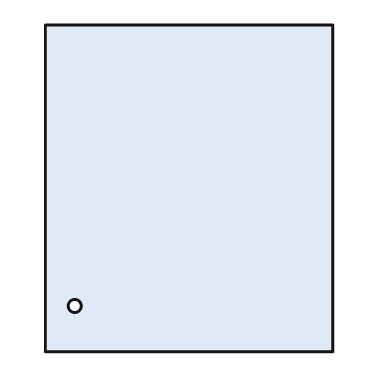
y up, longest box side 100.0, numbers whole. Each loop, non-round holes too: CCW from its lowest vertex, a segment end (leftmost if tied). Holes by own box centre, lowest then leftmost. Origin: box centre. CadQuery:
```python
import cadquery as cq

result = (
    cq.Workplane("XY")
    .moveTo(-44.0, -50.0)
    .lineTo(44.0, -50.0)
    .lineTo(44.0, 50.0)
    .lineTo(-44.0, 50.0)
    .close()
    .moveTo(-35.0, -36.0)
    .circle(2.0)
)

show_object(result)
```